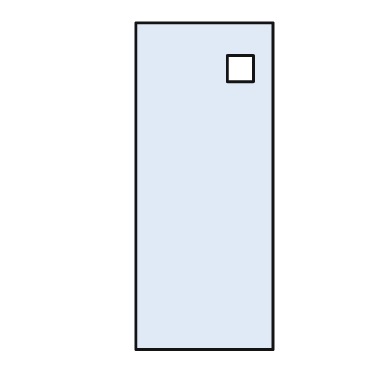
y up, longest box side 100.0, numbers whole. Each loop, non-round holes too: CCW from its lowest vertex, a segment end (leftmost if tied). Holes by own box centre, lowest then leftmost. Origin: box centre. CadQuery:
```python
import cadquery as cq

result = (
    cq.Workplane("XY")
    .moveTo(-21.0, -50.0)
    .lineTo(21.0, -50.0)
    .lineTo(21.0, 50.0)
    .lineTo(-21.0, 50.0)
    .close()
    .moveTo(7.0, 32.0)
    .lineTo(15.0, 32.0)
    .lineTo(15.0, 40.0)
    .lineTo(7.0, 40.0)
    .close()
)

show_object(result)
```